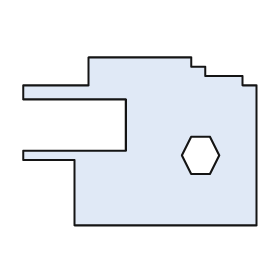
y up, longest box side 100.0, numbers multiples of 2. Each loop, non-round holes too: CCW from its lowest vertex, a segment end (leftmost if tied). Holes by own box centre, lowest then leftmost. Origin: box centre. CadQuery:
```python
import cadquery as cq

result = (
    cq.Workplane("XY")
    .moveTo(-28.0, -36.0)
    .lineTo(50.0, -36.0)
    .lineTo(50.0, 24.0)
    .lineTo(44.0, 24.0)
    .lineTo(44.0, 28.0)
    .lineTo(28.0, 28.0)
    .lineTo(28.0, 32.0)
    .lineTo(22.0, 32.0)
    .lineTo(22.0, 36.0)
    .lineTo(-22.0, 36.0)
    .lineTo(-22.0, 24.0)
    .lineTo(-50.0, 24.0)
    .lineTo(-50.0, 18.0)
    .lineTo(-6.0, 18.0)
    .lineTo(-6.0, -4.0)
    .lineTo(-50.0, -4.0)
    .lineTo(-50.0, -8.0)
    .lineTo(-28.0, -8.0)
    .close()
    .moveTo(22.0, -14.0)
    .lineTo(30.0, -14.0)
    .lineTo(34.0, -6.0)
    .lineTo(30.0, 2.0)
    .lineTo(22.0, 2.0)
    .lineTo(18.0, -6.0)
    .close()
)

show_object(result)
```